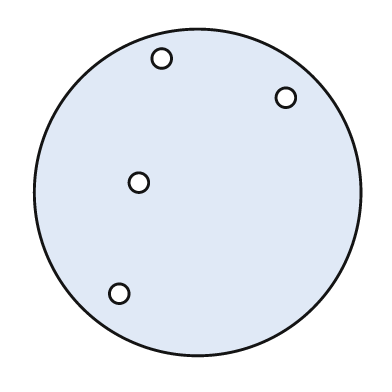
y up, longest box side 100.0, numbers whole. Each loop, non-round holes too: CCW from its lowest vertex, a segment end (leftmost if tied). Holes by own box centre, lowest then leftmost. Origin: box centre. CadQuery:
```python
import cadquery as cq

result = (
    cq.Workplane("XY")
    .moveTo(0.0, 0.0)
    .circle(50.0)
    .moveTo(-24.0, -31.0)
    .circle(3.0)
    .moveTo(-18.0, 3.0)
    .circle(3.0)
    .moveTo(27.0, 29.0)
    .circle(3.0)
    .moveTo(-11.0, 41.0)
    .circle(3.0)
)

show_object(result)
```